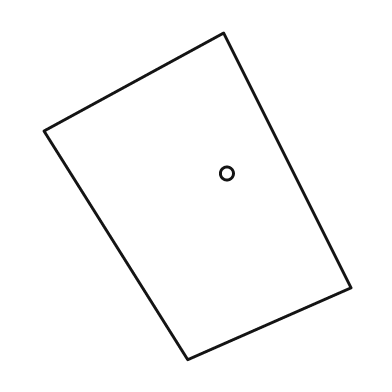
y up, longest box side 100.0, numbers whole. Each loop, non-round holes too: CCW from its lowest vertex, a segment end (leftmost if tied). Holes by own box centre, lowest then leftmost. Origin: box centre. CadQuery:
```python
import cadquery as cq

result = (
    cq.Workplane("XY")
    .moveTo(-3.0, -50.0)
    .lineTo(47.0, -28.0)
    .lineTo(8.0, 50.0)
    .lineTo(-47.0, 20.0)
    .close()
    .moveTo(9.0, 7.0)
    .circle(2.0)
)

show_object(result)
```